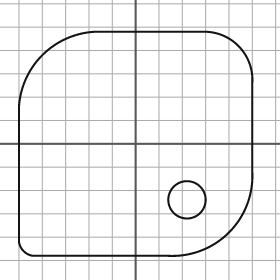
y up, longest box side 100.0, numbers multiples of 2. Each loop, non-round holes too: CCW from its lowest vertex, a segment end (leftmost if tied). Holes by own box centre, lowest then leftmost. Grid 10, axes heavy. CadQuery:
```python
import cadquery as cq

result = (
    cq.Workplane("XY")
    .moveTo(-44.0, -48.0)
    .lineTo(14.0, -48.0)
    .threePointArc((40.0, -38.0), (50.0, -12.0))
    .lineTo(50.0, 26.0)
    .threePointArc((44.0, 42.0), (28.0, 48.0))
    .lineTo(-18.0, 48.0)
    .threePointArc((-40.0, 38.0), (-50.0, 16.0))
    .lineTo(-50.0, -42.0)
    .threePointArc((-48.0, -46.0), (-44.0, -48.0))
    .close()
    .moveTo(22.0, -24.0)
    .circle(8.0)
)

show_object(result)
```